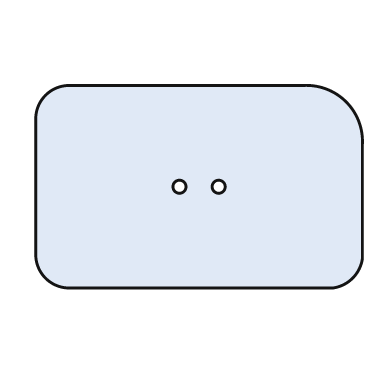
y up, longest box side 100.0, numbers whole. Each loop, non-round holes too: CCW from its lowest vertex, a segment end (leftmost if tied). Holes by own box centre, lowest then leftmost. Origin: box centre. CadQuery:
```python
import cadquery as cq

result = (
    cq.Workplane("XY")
    .moveTo(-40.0, -31.0)
    .lineTo(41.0, -31.0)
    .threePointArc((47.0, -28.0), (50.0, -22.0))
    .lineTo(50.0, 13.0)
    .threePointArc((45.0, 26.0), (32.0, 31.0))
    .lineTo(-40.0, 31.0)
    .threePointArc((-47.0, 28.0), (-50.0, 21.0))
    .lineTo(-50.0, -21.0)
    .threePointArc((-47.0, -28.0), (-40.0, -31.0))
    .close()
    .moveTo(-6.0, 0.0)
    .circle(2.0)
    .moveTo(6.0, 0.0)
    .circle(2.0)
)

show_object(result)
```